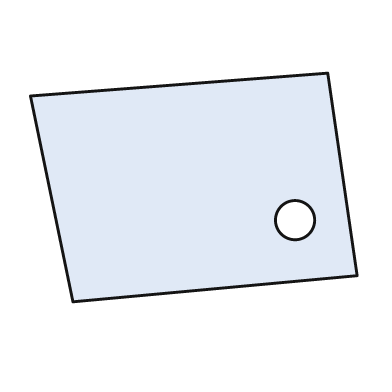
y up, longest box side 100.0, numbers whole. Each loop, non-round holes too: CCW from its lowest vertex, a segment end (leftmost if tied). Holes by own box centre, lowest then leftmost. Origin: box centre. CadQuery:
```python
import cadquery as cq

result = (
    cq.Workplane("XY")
    .moveTo(-37.0, -35.0)
    .lineTo(50.0, -27.0)
    .lineTo(41.0, 35.0)
    .lineTo(-50.0, 28.0)
    .close()
    .moveTo(31.0, -10.0)
    .circle(6.0)
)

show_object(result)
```